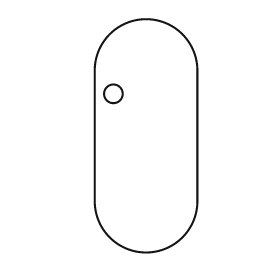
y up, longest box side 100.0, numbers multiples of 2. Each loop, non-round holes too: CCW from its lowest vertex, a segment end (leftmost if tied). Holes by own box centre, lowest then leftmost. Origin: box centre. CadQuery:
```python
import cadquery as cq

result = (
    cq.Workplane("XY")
    .moveTo(-22.0, -28.0)
    .threePointArc((0.0, -50.0), (22.0, -28.0))
    .lineTo(22.0, 28.0)
    .threePointArc((0.0, 50.0), (-22.0, 28.0))
    .close()
    .moveTo(-14.0, 18.0)
    .circle(4.0)
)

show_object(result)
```